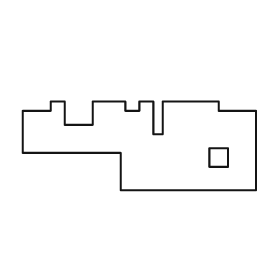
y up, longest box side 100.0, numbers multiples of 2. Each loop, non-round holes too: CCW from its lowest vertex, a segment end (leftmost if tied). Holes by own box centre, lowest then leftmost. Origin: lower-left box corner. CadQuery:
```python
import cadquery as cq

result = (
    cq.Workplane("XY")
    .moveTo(42.0, 0.0)
    .lineTo(100.0, 0.0)
    .lineTo(100.0, 34.0)
    .lineTo(84.0, 34.0)
    .lineTo(84.0, 38.0)
    .lineTo(60.0, 38.0)
    .lineTo(60.0, 24.0)
    .lineTo(56.0, 24.0)
    .lineTo(56.0, 38.0)
    .lineTo(50.0, 38.0)
    .lineTo(50.0, 34.0)
    .lineTo(44.0, 34.0)
    .lineTo(44.0, 38.0)
    .lineTo(30.0, 38.0)
    .lineTo(30.0, 28.0)
    .lineTo(18.0, 28.0)
    .lineTo(18.0, 38.0)
    .lineTo(12.0, 38.0)
    .lineTo(12.0, 34.0)
    .lineTo(0.0, 34.0)
    .lineTo(0.0, 16.0)
    .lineTo(42.0, 16.0)
    .close()
    .moveTo(80.0, 10.0)
    .lineTo(88.0, 10.0)
    .lineTo(88.0, 18.0)
    .lineTo(80.0, 18.0)
    .close()
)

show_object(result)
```